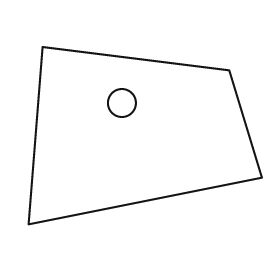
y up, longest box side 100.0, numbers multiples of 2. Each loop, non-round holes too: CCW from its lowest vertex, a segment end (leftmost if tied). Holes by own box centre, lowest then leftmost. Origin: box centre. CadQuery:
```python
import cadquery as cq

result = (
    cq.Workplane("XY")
    .moveTo(-50.0, -38.0)
    .lineTo(50.0, -18.0)
    .lineTo(36.0, 28.0)
    .lineTo(-44.0, 38.0)
    .close()
    .moveTo(-10.0, 14.0)
    .circle(6.0)
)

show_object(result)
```